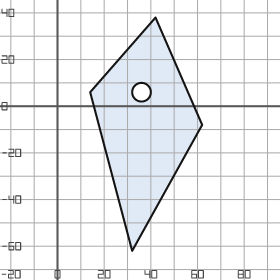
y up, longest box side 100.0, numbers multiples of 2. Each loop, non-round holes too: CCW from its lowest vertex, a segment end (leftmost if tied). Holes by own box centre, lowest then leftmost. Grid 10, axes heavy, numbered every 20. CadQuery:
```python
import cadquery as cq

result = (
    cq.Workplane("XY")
    .moveTo(32.0, -62.0)
    .lineTo(62.0, -8.0)
    .lineTo(42.0, 38.0)
    .lineTo(14.0, 6.0)
    .close()
    .moveTo(36.0, 6.0)
    .circle(4.0)
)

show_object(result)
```